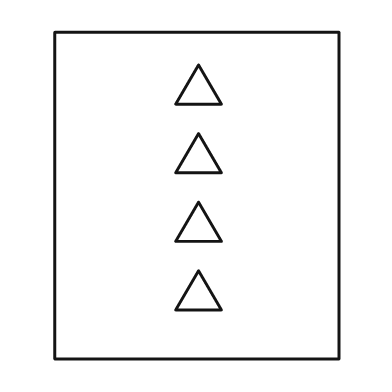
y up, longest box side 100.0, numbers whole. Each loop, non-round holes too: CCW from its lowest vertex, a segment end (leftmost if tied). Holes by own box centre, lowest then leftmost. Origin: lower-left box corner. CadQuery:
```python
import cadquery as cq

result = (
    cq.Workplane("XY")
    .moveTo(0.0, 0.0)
    .lineTo(87.0, 0.0)
    .lineTo(87.0, 100.0)
    .lineTo(0.0, 100.0)
    .close()
    .moveTo(37.0, 15.0)
    .lineTo(51.0, 15.0)
    .lineTo(44.0, 27.0)
    .close()
    .moveTo(37.0, 36.0)
    .lineTo(51.0, 36.0)
    .lineTo(44.0, 48.0)
    .close()
    .moveTo(37.0, 57.0)
    .lineTo(51.0, 57.0)
    .lineTo(44.0, 69.0)
    .close()
    .moveTo(37.0, 78.0)
    .lineTo(51.0, 78.0)
    .lineTo(44.0, 90.0)
    .close()
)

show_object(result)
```